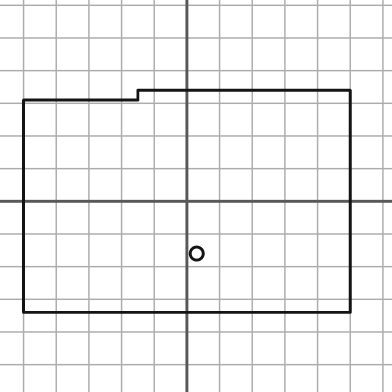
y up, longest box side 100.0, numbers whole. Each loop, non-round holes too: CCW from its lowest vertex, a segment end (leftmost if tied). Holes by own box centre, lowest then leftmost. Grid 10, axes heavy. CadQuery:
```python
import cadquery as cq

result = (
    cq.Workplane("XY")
    .moveTo(-50.0, -34.0)
    .lineTo(50.0, -34.0)
    .lineTo(50.0, 34.0)
    .lineTo(-15.0, 34.0)
    .lineTo(-15.0, 31.0)
    .lineTo(-50.0, 31.0)
    .close()
    .moveTo(3.0, -16.0)
    .circle(2.0)
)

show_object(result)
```